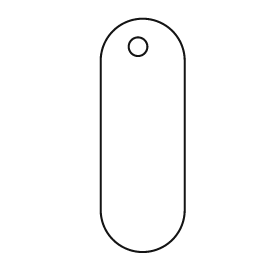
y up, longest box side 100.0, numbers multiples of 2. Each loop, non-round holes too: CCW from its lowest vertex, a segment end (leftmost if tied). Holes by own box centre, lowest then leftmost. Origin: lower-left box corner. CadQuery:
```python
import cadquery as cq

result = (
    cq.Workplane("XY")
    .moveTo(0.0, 18.0)
    .threePointArc((18.0, 0.0), (36.0, 18.0))
    .lineTo(36.0, 82.0)
    .threePointArc((18.0, 100.0), (0.0, 82.0))
    .close()
    .moveTo(16.0, 88.0)
    .circle(4.0)
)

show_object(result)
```